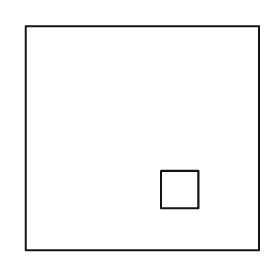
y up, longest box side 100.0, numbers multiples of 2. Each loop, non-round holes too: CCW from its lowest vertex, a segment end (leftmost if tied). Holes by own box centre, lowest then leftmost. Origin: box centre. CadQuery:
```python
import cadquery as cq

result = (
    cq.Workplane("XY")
    .moveTo(-50.0, -48.0)
    .lineTo(50.0, -48.0)
    .lineTo(50.0, 48.0)
    .lineTo(-50.0, 48.0)
    .close()
    .moveTo(8.0, -30.0)
    .lineTo(24.0, -30.0)
    .lineTo(24.0, -14.0)
    .lineTo(8.0, -14.0)
    .close()
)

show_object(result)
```